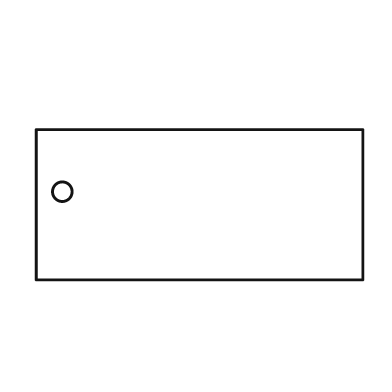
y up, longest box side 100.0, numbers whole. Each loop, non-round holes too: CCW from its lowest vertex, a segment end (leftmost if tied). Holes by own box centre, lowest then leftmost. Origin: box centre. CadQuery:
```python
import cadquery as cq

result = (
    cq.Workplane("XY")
    .moveTo(-50.0, -23.0)
    .lineTo(50.0, -23.0)
    .lineTo(50.0, 23.0)
    .lineTo(-50.0, 23.0)
    .close()
    .moveTo(-42.0, 4.0)
    .circle(3.0)
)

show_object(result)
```